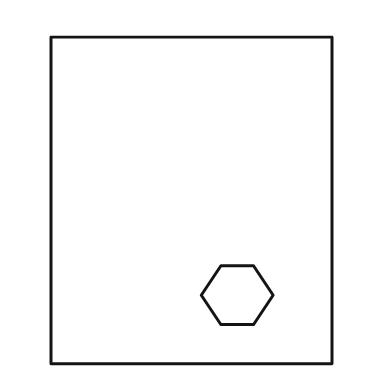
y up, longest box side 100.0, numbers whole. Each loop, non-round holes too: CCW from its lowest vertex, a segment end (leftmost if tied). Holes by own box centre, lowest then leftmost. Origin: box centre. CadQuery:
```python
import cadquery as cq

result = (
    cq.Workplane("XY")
    .moveTo(-43.0, -50.0)
    .lineTo(43.0, -50.0)
    .lineTo(43.0, 50.0)
    .lineTo(-43.0, 50.0)
    .close()
    .moveTo(9.0, -38.0)
    .lineTo(19.0, -38.0)
    .lineTo(25.0, -29.0)
    .lineTo(19.0, -20.0)
    .lineTo(9.0, -20.0)
    .lineTo(3.0, -29.0)
    .close()
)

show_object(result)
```